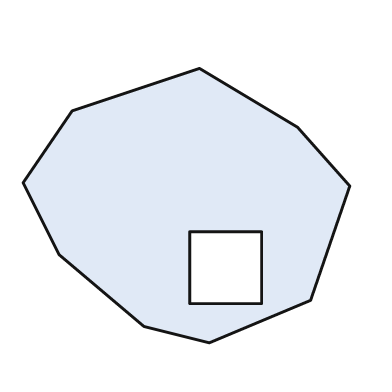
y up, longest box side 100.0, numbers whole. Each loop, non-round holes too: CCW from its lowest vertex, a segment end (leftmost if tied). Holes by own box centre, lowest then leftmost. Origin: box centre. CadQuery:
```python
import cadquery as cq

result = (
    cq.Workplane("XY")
    .moveTo(7.0, -42.0)
    .lineTo(38.0, -29.0)
    .lineTo(50.0, 6.0)
    .lineTo(34.0, 24.0)
    .lineTo(4.0, 42.0)
    .lineTo(-35.0, 29.0)
    .lineTo(-50.0, 7.0)
    .lineTo(-39.0, -15.0)
    .lineTo(-13.0, -37.0)
    .close()
    .moveTo(1.0, -30.0)
    .lineTo(23.0, -30.0)
    .lineTo(23.0, -8.0)
    .lineTo(1.0, -8.0)
    .close()
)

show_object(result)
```